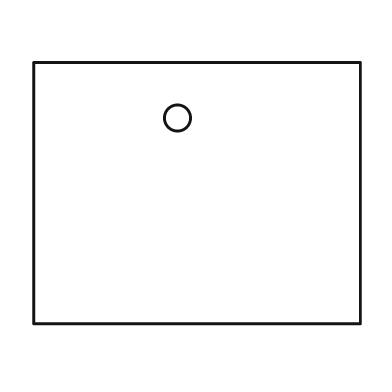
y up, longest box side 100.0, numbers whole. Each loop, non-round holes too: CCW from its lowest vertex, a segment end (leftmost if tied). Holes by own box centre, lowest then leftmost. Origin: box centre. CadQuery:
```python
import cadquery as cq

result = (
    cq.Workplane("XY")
    .moveTo(-50.0, -40.0)
    .lineTo(50.0, -40.0)
    .lineTo(50.0, 40.0)
    .lineTo(-50.0, 40.0)
    .close()
    .moveTo(-6.0, 23.0)
    .circle(4.0)
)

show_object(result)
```